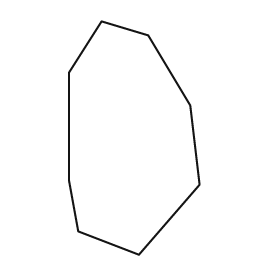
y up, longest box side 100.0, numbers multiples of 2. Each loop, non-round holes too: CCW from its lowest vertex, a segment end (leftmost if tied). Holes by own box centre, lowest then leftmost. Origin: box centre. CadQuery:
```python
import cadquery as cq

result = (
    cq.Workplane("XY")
    .moveTo(2.0, -50.0)
    .lineTo(28.0, -20.0)
    .lineTo(24.0, 14.0)
    .lineTo(6.0, 44.0)
    .lineTo(-14.0, 50.0)
    .lineTo(-28.0, 28.0)
    .lineTo(-28.0, -18.0)
    .lineTo(-24.0, -40.0)
    .close()
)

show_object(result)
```